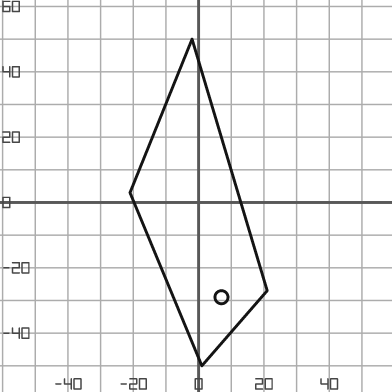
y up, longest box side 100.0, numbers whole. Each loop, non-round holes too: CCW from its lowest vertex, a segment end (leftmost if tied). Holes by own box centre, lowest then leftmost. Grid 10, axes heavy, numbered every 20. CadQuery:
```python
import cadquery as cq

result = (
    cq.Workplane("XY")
    .moveTo(1.0, -50.0)
    .lineTo(21.0, -27.0)
    .lineTo(-2.0, 50.0)
    .lineTo(-21.0, 3.0)
    .close()
    .moveTo(7.0, -29.0)
    .circle(2.0)
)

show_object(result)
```